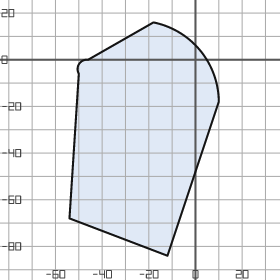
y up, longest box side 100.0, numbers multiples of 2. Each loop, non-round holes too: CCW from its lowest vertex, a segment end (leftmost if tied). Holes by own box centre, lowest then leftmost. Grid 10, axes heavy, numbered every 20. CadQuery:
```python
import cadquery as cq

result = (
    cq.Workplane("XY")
    .moveTo(-12.0, -84.0)
    .lineTo(10.0, -18.0)
    .threePointArc((2.0, 4.0), (-18.0, 16.0))
    .lineTo(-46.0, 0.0)
    .threePointArc((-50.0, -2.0), (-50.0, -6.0))
    .lineTo(-54.0, -68.0)
    .close()
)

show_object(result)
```